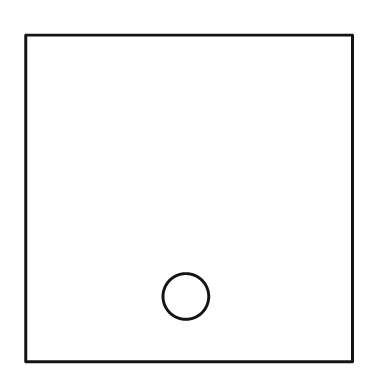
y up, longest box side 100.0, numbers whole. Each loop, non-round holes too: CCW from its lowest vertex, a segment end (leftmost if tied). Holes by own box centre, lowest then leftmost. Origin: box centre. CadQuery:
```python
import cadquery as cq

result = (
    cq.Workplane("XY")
    .moveTo(-50.0, -50.0)
    .lineTo(50.0, -50.0)
    .lineTo(50.0, 50.0)
    .lineTo(-50.0, 50.0)
    .close()
    .moveTo(-1.0, -30.0)
    .circle(7.0)
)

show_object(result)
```